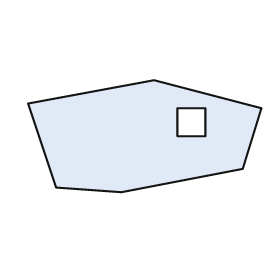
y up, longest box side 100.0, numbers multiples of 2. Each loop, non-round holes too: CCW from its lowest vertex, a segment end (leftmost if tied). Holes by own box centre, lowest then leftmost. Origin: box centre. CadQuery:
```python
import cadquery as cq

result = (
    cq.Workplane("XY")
    .moveTo(-10.0, -24.0)
    .lineTo(42.0, -14.0)
    .lineTo(50.0, 12.0)
    .lineTo(4.0, 24.0)
    .lineTo(-50.0, 14.0)
    .lineTo(-38.0, -22.0)
    .close()
    .moveTo(14.0, 0.0)
    .lineTo(26.0, 0.0)
    .lineTo(26.0, 12.0)
    .lineTo(14.0, 12.0)
    .close()
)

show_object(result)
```